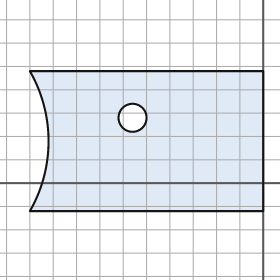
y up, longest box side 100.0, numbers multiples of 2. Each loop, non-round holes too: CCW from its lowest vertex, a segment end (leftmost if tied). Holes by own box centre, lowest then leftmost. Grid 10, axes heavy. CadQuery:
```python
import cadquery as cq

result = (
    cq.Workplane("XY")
    .moveTo(-100.0, -12.0)
    .lineTo(0.0, -12.0)
    .lineTo(0.0, 48.0)
    .lineTo(-100.0, 48.0)
    .threePointArc((-92.0, 18.0), (-100.0, -12.0))
    .close()
    .moveTo(-56.0, 28.0)
    .circle(6.0)
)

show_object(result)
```